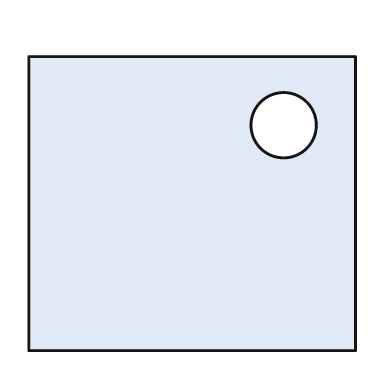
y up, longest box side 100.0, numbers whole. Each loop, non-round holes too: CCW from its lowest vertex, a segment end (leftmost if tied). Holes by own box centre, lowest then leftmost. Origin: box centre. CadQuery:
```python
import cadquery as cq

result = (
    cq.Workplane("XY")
    .moveTo(-50.0, -45.0)
    .lineTo(50.0, -45.0)
    .lineTo(50.0, 45.0)
    .lineTo(-50.0, 45.0)
    .close()
    .moveTo(28.0, 24.0)
    .circle(10.0)
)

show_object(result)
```